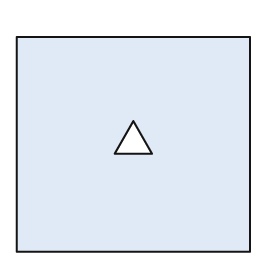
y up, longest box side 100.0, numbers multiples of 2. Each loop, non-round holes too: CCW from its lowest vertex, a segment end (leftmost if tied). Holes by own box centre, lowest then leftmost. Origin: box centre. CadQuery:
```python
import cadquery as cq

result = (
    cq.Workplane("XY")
    .moveTo(-50.0, -46.0)
    .lineTo(50.0, -46.0)
    .lineTo(50.0, 46.0)
    .lineTo(-50.0, 46.0)
    .close()
    .moveTo(-8.0, -4.0)
    .lineTo(8.0, -4.0)
    .lineTo(0.0, 10.0)
    .close()
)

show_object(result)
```